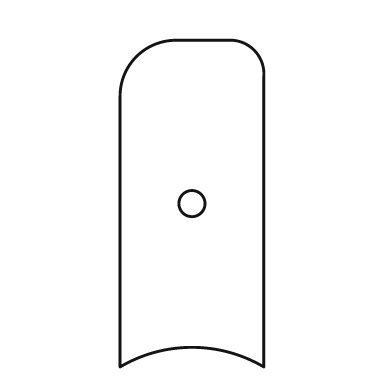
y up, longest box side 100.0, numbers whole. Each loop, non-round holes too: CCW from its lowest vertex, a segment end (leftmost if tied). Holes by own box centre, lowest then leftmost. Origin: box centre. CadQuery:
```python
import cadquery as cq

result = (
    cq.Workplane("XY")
    .moveTo(-22.0, -50.0)
    .threePointArc((0.0, -44.0), (22.0, -50.0))
    .lineTo(22.0, 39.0)
    .threePointArc((19.0, 47.0), (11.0, 50.0))
    .lineTo(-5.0, 50.0)
    .threePointArc((-17.0, 45.0), (-22.0, 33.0))
    .close()
    .moveTo(0.0, 0.0)
    .circle(4.0)
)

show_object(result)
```